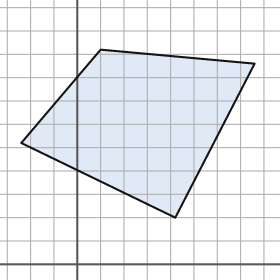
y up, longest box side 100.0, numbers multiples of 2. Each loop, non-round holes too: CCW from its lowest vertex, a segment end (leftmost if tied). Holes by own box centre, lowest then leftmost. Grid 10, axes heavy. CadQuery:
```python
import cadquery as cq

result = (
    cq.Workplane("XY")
    .moveTo(42.0, 20.0)
    .lineTo(76.0, 86.0)
    .lineTo(10.0, 92.0)
    .lineTo(-24.0, 52.0)
    .close()
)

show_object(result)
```